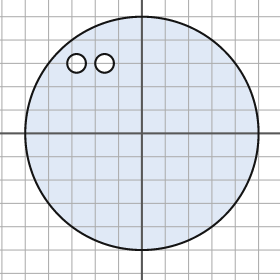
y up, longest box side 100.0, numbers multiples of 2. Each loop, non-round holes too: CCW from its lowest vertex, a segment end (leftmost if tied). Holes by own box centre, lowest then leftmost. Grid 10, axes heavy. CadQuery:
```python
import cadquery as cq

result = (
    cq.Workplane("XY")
    .moveTo(0.0, 0.0)
    .circle(50.0)
    .moveTo(-28.0, 30.0)
    .circle(4.0)
    .moveTo(-16.0, 30.0)
    .circle(4.0)
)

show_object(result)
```